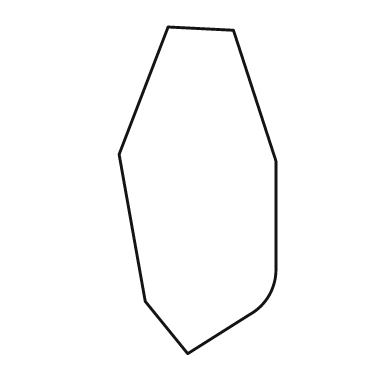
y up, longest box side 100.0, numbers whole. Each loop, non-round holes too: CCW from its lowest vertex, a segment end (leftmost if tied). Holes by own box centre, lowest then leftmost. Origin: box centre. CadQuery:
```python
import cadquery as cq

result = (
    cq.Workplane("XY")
    .moveTo(-3.0, -50.0)
    .lineTo(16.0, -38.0)
    .threePointArc((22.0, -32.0), (24.0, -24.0))
    .lineTo(24.0, 9.0)
    .lineTo(11.0, 49.0)
    .lineTo(-9.0, 50.0)
    .lineTo(-24.0, 11.0)
    .lineTo(-16.0, -34.0)
    .close()
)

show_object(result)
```